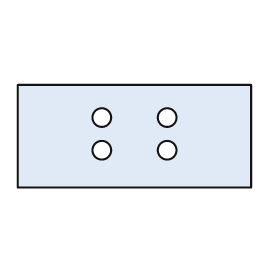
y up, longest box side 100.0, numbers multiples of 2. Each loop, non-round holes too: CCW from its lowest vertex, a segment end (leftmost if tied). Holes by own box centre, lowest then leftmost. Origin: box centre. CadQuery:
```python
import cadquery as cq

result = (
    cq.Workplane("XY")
    .moveTo(-50.0, -22.0)
    .lineTo(50.0, -22.0)
    .lineTo(50.0, 22.0)
    .lineTo(-50.0, 22.0)
    .close()
    .moveTo(-14.0, -6.0)
    .circle(4.0)
    .moveTo(14.0, -6.0)
    .circle(4.0)
    .moveTo(-14.0, 8.0)
    .circle(4.0)
    .moveTo(14.0, 8.0)
    .circle(4.0)
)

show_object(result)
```